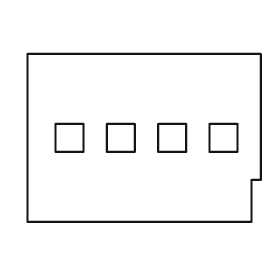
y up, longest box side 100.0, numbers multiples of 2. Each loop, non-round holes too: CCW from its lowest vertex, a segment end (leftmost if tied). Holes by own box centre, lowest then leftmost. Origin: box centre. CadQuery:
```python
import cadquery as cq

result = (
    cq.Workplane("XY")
    .moveTo(-50.0, -36.0)
    .lineTo(46.0, -36.0)
    .lineTo(46.0, -18.0)
    .lineTo(50.0, -18.0)
    .lineTo(50.0, 36.0)
    .lineTo(-50.0, 36.0)
    .close()
    .moveTo(-38.0, -6.0)
    .lineTo(-26.0, -6.0)
    .lineTo(-26.0, 6.0)
    .lineTo(-38.0, 6.0)
    .close()
    .moveTo(-16.0, -6.0)
    .lineTo(-4.0, -6.0)
    .lineTo(-4.0, 6.0)
    .lineTo(-16.0, 6.0)
    .close()
    .moveTo(6.0, -6.0)
    .lineTo(18.0, -6.0)
    .lineTo(18.0, 6.0)
    .lineTo(6.0, 6.0)
    .close()
    .moveTo(28.0, -6.0)
    .lineTo(40.0, -6.0)
    .lineTo(40.0, 6.0)
    .lineTo(28.0, 6.0)
    .close()
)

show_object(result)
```